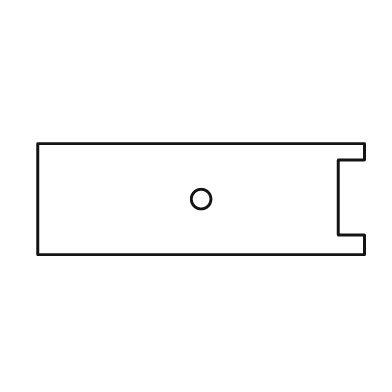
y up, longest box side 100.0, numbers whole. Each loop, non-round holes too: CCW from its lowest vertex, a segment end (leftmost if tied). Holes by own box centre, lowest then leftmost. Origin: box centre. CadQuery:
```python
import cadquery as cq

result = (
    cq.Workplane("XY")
    .moveTo(-50.0, -17.0)
    .lineTo(50.0, -17.0)
    .lineTo(50.0, -11.0)
    .lineTo(42.0, -11.0)
    .lineTo(42.0, 12.0)
    .lineTo(50.0, 12.0)
    .lineTo(50.0, 17.0)
    .lineTo(-50.0, 17.0)
    .close()
    .moveTo(0.0, 0.0)
    .circle(3.0)
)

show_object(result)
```